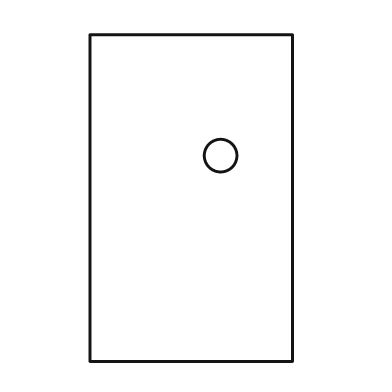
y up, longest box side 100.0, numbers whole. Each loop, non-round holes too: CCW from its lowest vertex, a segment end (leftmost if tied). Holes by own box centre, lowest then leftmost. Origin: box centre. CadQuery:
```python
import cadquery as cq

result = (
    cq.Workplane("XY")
    .moveTo(-31.0, -50.0)
    .lineTo(31.0, -50.0)
    .lineTo(31.0, 50.0)
    .lineTo(-31.0, 50.0)
    .close()
    .moveTo(9.0, 13.0)
    .circle(5.0)
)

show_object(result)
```